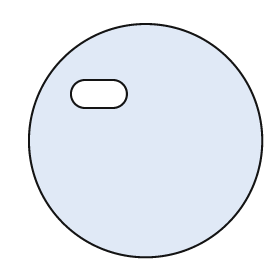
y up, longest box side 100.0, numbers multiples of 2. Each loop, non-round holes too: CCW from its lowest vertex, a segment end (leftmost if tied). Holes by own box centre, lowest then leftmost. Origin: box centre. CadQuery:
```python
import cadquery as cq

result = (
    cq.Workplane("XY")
    .moveTo(0.0, 0.0)
    .circle(50.0)
    .moveTo(-26.0, 14.0)
    .lineTo(-14.0, 14.0)
    .threePointArc((-8.0, 20.0), (-14.0, 26.0))
    .lineTo(-26.0, 26.0)
    .threePointArc((-32.0, 20.0), (-26.0, 14.0))
    .close()
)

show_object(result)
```